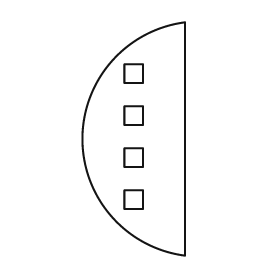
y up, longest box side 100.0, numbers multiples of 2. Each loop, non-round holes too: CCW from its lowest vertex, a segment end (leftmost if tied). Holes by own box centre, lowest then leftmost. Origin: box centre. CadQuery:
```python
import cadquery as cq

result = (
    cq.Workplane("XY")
    .moveTo(22.0, -50.0)
    .lineTo(22.0, 50.0)
    .threePointArc((-22.0, 0.0), (22.0, -50.0))
    .close()
    .moveTo(-4.0, -30.0)
    .lineTo(4.0, -30.0)
    .lineTo(4.0, -22.0)
    .lineTo(-4.0, -22.0)
    .close()
    .moveTo(-4.0, -12.0)
    .lineTo(4.0, -12.0)
    .lineTo(4.0, -4.0)
    .lineTo(-4.0, -4.0)
    .close()
    .moveTo(-4.0, 6.0)
    .lineTo(4.0, 6.0)
    .lineTo(4.0, 14.0)
    .lineTo(-4.0, 14.0)
    .close()
    .moveTo(-4.0, 24.0)
    .lineTo(4.0, 24.0)
    .lineTo(4.0, 32.0)
    .lineTo(-4.0, 32.0)
    .close()
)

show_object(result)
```